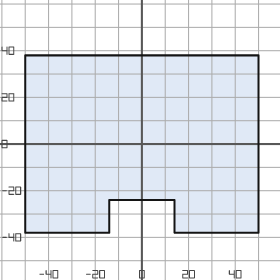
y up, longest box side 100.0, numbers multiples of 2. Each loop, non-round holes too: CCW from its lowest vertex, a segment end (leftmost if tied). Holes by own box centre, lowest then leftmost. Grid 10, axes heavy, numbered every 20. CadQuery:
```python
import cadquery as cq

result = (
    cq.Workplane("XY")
    .moveTo(-50.0, -38.0)
    .lineTo(-14.0, -38.0)
    .lineTo(-14.0, -24.0)
    .lineTo(14.0, -24.0)
    .lineTo(14.0, -38.0)
    .lineTo(50.0, -38.0)
    .lineTo(50.0, 38.0)
    .lineTo(-50.0, 38.0)
    .close()
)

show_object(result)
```